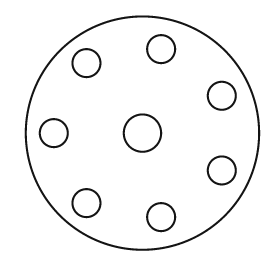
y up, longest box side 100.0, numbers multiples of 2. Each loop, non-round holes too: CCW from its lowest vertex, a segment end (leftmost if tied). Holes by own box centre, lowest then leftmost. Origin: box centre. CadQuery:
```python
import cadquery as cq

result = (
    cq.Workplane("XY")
    .moveTo(0.0, 0.0)
    .circle(50.0)
    .moveTo(8.0, -36.0)
    .circle(6.0)
    .moveTo(-24.0, -30.0)
    .circle(6.0)
    .moveTo(34.0, -16.0)
    .circle(6.0)
    .moveTo(-38.0, 0.0)
    .circle(6.0)
    .moveTo(0.0, 0.0)
    .circle(8.0)
    .moveTo(34.0, 16.0)
    .circle(6.0)
    .moveTo(-24.0, 30.0)
    .circle(6.0)
    .moveTo(8.0, 36.0)
    .circle(6.0)
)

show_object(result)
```